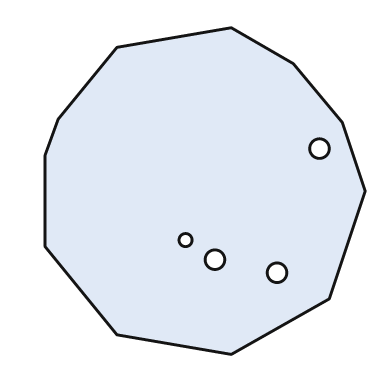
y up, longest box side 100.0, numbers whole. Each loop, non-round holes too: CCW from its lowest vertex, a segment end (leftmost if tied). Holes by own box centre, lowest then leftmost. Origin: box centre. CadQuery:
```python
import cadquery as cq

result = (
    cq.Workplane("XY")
    .moveTo(8.0, -50.0)
    .lineTo(38.0, -33.0)
    .lineTo(49.0, 0.0)
    .lineTo(42.0, 21.0)
    .lineTo(27.0, 39.0)
    .lineTo(8.0, 50.0)
    .lineTo(-27.0, 44.0)
    .lineTo(-45.0, 22.0)
    .lineTo(-49.0, 11.0)
    .lineTo(-49.0, -17.0)
    .lineTo(-27.0, -44.0)
    .close()
    .moveTo(22.0, -25.0)
    .circle(3.0)
    .moveTo(3.0, -21.0)
    .circle(3.0)
    .moveTo(-6.0, -15.0)
    .circle(2.0)
    .moveTo(35.0, 13.0)
    .circle(3.0)
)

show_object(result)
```